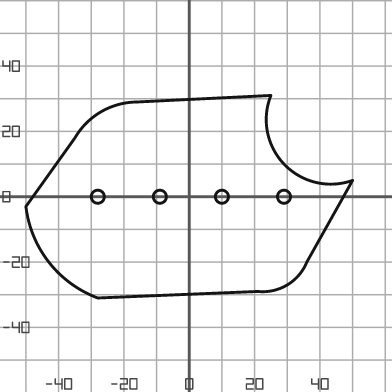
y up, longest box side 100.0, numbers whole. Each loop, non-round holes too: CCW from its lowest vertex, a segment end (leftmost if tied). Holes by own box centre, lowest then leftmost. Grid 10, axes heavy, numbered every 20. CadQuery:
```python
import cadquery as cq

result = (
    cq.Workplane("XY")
    .moveTo(-28.0, -31.0)
    .lineTo(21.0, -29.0)
    .threePointArc((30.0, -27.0), (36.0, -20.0))
    .lineTo(50.0, 5.0)
    .threePointArc((29.0, 10.0), (25.0, 31.0))
    .lineTo(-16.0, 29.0)
    .threePointArc((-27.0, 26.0), (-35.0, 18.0))
    .lineTo(-50.0, -3.0)
    .threePointArc((-43.0, -20.0), (-28.0, -31.0))
    .close()
    .moveTo(-28.0, 0.0)
    .circle(2.0)
    .moveTo(-9.0, 0.0)
    .circle(2.0)
    .moveTo(10.0, 0.0)
    .circle(2.0)
    .moveTo(29.0, 0.0)
    .circle(2.0)
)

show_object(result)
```